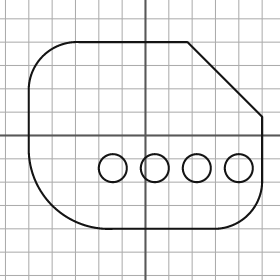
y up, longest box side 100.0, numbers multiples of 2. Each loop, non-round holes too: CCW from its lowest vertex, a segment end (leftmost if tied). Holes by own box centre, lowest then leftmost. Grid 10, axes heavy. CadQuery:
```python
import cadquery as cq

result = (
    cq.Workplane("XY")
    .moveTo(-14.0, -40.0)
    .lineTo(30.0, -40.0)
    .threePointArc((44.0, -34.0), (50.0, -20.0))
    .lineTo(50.0, 8.0)
    .lineTo(18.0, 40.0)
    .lineTo(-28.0, 40.0)
    .threePointArc((-44.0, 34.0), (-50.0, 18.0))
    .lineTo(-50.0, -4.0)
    .threePointArc((-40.0, -30.0), (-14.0, -40.0))
    .close()
    .moveTo(-14.0, -14.0)
    .circle(6.0)
    .moveTo(4.0, -14.0)
    .circle(6.0)
    .moveTo(22.0, -14.0)
    .circle(6.0)
    .moveTo(40.0, -14.0)
    .circle(6.0)
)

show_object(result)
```